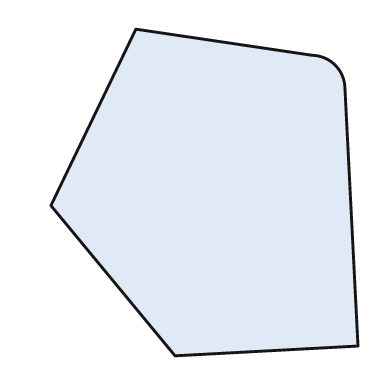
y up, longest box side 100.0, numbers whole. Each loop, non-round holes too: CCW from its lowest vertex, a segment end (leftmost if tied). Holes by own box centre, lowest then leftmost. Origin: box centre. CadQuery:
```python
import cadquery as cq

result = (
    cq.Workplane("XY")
    .moveTo(-9.0, -50.0)
    .lineTo(47.0, -47.0)
    .lineTo(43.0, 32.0)
    .threePointArc((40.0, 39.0), (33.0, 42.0))
    .lineTo(-21.0, 50.0)
    .lineTo(-47.0, -4.0)
    .close()
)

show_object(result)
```